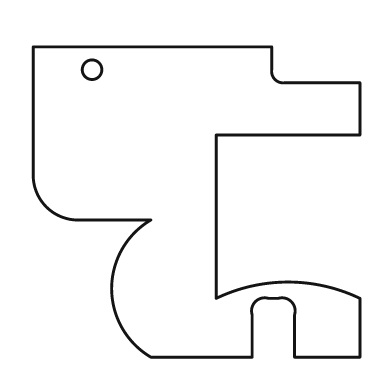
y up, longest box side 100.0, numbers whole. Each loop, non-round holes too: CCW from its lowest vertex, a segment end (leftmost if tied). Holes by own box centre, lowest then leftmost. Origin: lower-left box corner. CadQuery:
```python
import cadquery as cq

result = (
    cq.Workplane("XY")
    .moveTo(36.0, 0.0)
    .lineTo(67.0, 0.0)
    .lineTo(67.0, 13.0)
    .threePointArc((68.0, 17.0), (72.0, 18.0))
    .lineTo(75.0, 18.0)
    .threePointArc((79.0, 17.0), (80.0, 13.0))
    .lineTo(80.0, 0.0)
    .lineTo(100.0, 0.0)
    .lineTo(100.0, 18.0)
    .threePointArc((78.0, 23.0), (56.0, 18.0))
    .lineTo(56.0, 68.0)
    .lineTo(100.0, 68.0)
    .lineTo(100.0, 84.0)
    .lineTo(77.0, 84.0)
    .threePointArc((74.0, 85.0), (73.0, 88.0))
    .lineTo(73.0, 95.0)
    .lineTo(0.0, 95.0)
    .lineTo(0.0, 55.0)
    .threePointArc((4.0, 46.0), (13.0, 42.0))
    .lineTo(36.0, 42.0)
    .threePointArc((24.0, 21.0), (36.0, 0.0))
    .close()
    .moveTo(18.0, 88.0)
    .circle(3.0)
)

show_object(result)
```